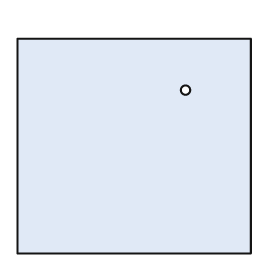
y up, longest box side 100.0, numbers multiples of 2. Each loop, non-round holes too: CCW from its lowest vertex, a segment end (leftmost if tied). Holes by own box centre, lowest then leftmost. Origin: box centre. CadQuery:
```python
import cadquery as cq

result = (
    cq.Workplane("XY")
    .moveTo(-50.0, -46.0)
    .lineTo(50.0, -46.0)
    .lineTo(50.0, 46.0)
    .lineTo(-50.0, 46.0)
    .close()
    .moveTo(22.0, 24.0)
    .circle(2.0)
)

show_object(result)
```